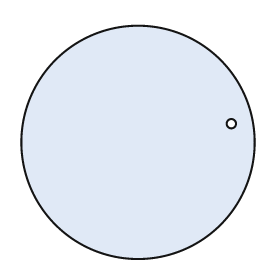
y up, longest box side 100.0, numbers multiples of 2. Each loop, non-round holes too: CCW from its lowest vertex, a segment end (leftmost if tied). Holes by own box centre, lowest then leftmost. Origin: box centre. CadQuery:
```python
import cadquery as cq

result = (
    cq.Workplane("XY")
    .moveTo(0.0, 0.0)
    .circle(50.0)
    .moveTo(40.0, 8.0)
    .circle(2.0)
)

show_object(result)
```